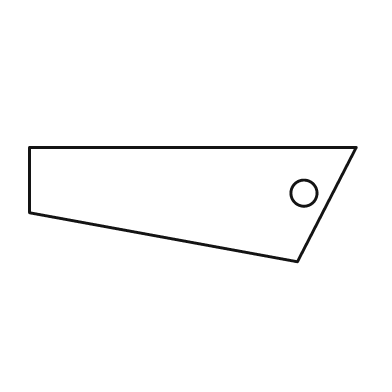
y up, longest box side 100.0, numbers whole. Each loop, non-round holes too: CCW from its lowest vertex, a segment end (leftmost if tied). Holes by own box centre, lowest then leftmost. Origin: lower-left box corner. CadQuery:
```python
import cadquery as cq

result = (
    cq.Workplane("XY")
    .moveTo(82.0, 0.0)
    .lineTo(100.0, 35.0)
    .lineTo(0.0, 35.0)
    .lineTo(0.0, 15.0)
    .close()
    .moveTo(84.0, 21.0)
    .circle(4.0)
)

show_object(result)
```